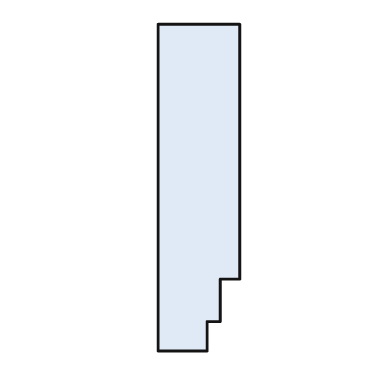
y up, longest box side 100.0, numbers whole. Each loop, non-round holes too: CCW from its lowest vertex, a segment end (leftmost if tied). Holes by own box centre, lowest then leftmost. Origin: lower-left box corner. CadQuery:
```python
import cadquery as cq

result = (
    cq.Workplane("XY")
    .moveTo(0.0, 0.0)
    .lineTo(15.0, 0.0)
    .lineTo(15.0, 9.0)
    .lineTo(19.0, 9.0)
    .lineTo(19.0, 22.0)
    .lineTo(25.0, 22.0)
    .lineTo(25.0, 100.0)
    .lineTo(0.0, 100.0)
    .close()
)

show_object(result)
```